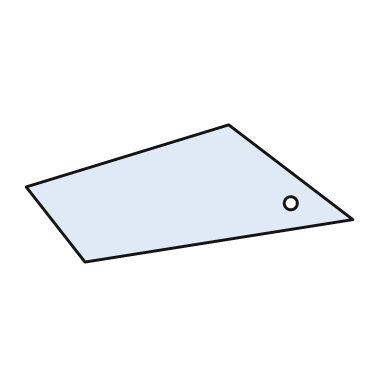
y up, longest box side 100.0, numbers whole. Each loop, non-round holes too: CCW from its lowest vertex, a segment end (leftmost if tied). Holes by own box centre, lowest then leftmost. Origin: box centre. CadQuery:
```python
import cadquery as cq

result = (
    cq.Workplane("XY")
    .moveTo(-32.0, -21.0)
    .lineTo(50.0, -8.0)
    .lineTo(12.0, 21.0)
    .lineTo(-50.0, 2.0)
    .close()
    .moveTo(31.0, -3.0)
    .circle(2.0)
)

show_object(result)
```